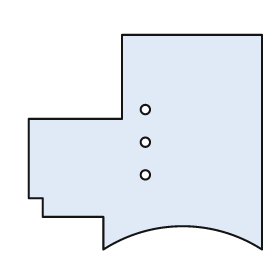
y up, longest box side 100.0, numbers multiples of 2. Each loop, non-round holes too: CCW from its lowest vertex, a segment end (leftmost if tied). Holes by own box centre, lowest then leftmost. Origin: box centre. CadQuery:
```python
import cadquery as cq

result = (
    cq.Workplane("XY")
    .moveTo(-18.0, -46.0)
    .threePointArc((16.0, -36.0), (50.0, -46.0))
    .lineTo(50.0, 46.0)
    .lineTo(-10.0, 46.0)
    .lineTo(-10.0, 10.0)
    .lineTo(-50.0, 10.0)
    .lineTo(-50.0, -24.0)
    .lineTo(-44.0, -24.0)
    .lineTo(-44.0, -32.0)
    .lineTo(-18.0, -32.0)
    .close()
    .moveTo(0.0, -14.0)
    .circle(2.0)
    .moveTo(0.0, 0.0)
    .circle(2.0)
    .moveTo(0.0, 14.0)
    .circle(2.0)
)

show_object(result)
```